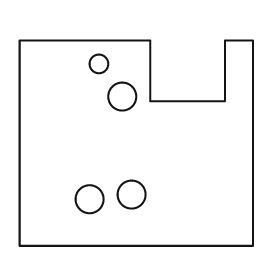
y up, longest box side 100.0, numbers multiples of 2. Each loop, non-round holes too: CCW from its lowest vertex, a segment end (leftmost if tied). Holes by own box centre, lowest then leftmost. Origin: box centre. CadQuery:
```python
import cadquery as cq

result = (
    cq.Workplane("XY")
    .moveTo(-50.0, -44.0)
    .lineTo(50.0, -44.0)
    .lineTo(50.0, 44.0)
    .lineTo(38.0, 44.0)
    .lineTo(38.0, 18.0)
    .lineTo(6.0, 18.0)
    .lineTo(6.0, 44.0)
    .lineTo(-50.0, 44.0)
    .close()
    .moveTo(-20.0, -24.0)
    .circle(6.0)
    .moveTo(-2.0, -22.0)
    .circle(6.0)
    .moveTo(-6.0, 20.0)
    .circle(6.0)
    .moveTo(-16.0, 34.0)
    .circle(4.0)
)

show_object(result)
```